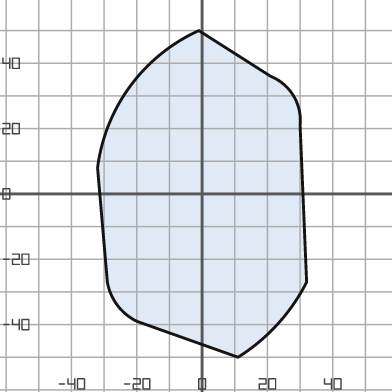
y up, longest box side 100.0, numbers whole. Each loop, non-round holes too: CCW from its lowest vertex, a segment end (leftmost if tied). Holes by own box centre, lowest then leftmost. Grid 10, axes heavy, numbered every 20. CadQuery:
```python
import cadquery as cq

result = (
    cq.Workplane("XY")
    .moveTo(11.0, -50.0)
    .threePointArc((23.0, -40.0), (32.0, -27.0))
    .lineTo(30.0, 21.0)
    .threePointArc((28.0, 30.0), (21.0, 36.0))
    .lineTo(-1.0, 50.0)
    .threePointArc((-22.0, 33.0), (-32.0, 8.0))
    .lineTo(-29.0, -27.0)
    .threePointArc((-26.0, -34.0), (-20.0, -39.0))
    .close()
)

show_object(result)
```